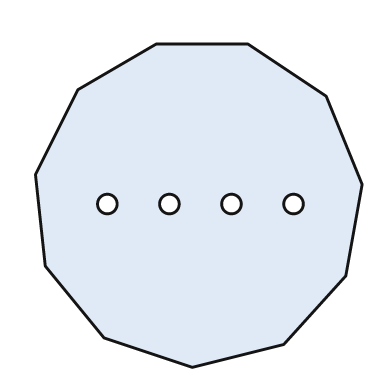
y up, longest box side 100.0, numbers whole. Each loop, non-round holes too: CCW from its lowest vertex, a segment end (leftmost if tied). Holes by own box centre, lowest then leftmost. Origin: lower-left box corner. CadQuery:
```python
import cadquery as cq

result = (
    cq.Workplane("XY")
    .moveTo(48.0, 0.0)
    .lineTo(76.0, 7.0)
    .lineTo(95.0, 28.0)
    .lineTo(100.0, 56.0)
    .lineTo(89.0, 83.0)
    .lineTo(65.0, 99.0)
    .lineTo(37.0, 99.0)
    .lineTo(13.0, 85.0)
    .lineTo(0.0, 59.0)
    .lineTo(3.0, 31.0)
    .lineTo(21.0, 9.0)
    .close()
    .moveTo(22.0, 50.0)
    .circle(3.0)
    .moveTo(41.0, 50.0)
    .circle(3.0)
    .moveTo(60.0, 50.0)
    .circle(3.0)
    .moveTo(79.0, 50.0)
    .circle(3.0)
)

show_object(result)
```